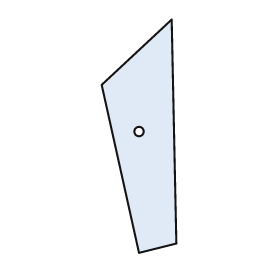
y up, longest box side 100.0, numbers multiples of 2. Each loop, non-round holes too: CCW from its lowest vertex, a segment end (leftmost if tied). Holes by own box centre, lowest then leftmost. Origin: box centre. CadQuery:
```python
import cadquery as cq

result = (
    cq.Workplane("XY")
    .moveTo(0.0, -50.0)
    .lineTo(16.0, -46.0)
    .lineTo(14.0, 50.0)
    .lineTo(-16.0, 22.0)
    .close()
    .moveTo(0.0, 2.0)
    .circle(2.0)
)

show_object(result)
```